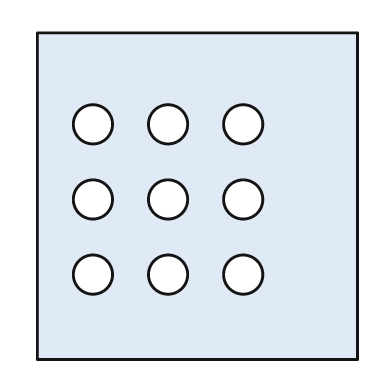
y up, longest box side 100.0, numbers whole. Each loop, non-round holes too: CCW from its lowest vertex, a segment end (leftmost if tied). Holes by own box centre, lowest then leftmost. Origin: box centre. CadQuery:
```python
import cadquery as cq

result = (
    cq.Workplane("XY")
    .moveTo(-49.0, -50.0)
    .lineTo(49.0, -50.0)
    .lineTo(49.0, 50.0)
    .lineTo(-49.0, 50.0)
    .close()
    .moveTo(-32.0, -24.0)
    .circle(6.0)
    .moveTo(-9.0, -24.0)
    .circle(6.0)
    .moveTo(14.0, -24.0)
    .circle(6.0)
    .moveTo(-32.0, -1.0)
    .circle(6.0)
    .moveTo(-9.0, -1.0)
    .circle(6.0)
    .moveTo(14.0, -1.0)
    .circle(6.0)
    .moveTo(-32.0, 22.0)
    .circle(6.0)
    .moveTo(-9.0, 22.0)
    .circle(6.0)
    .moveTo(14.0, 22.0)
    .circle(6.0)
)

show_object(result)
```